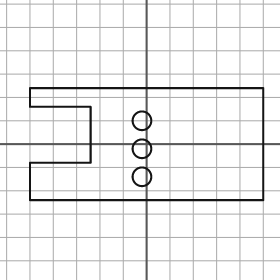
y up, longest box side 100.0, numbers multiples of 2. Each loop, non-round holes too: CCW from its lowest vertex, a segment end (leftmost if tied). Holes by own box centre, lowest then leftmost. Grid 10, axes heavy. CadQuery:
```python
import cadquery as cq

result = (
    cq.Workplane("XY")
    .moveTo(-50.0, -24.0)
    .lineTo(50.0, -24.0)
    .lineTo(50.0, 24.0)
    .lineTo(-50.0, 24.0)
    .lineTo(-50.0, 16.0)
    .lineTo(-24.0, 16.0)
    .lineTo(-24.0, -8.0)
    .lineTo(-50.0, -8.0)
    .close()
    .moveTo(-2.0, -14.0)
    .circle(4.0)
    .moveTo(-2.0, -2.0)
    .circle(4.0)
    .moveTo(-2.0, 10.0)
    .circle(4.0)
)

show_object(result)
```